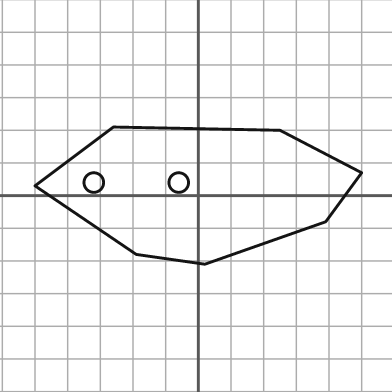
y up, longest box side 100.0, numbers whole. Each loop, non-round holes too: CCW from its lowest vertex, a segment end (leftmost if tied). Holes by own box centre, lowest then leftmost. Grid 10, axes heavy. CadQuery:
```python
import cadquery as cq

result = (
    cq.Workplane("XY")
    .moveTo(2.0, -21.0)
    .lineTo(39.0, -8.0)
    .lineTo(50.0, 7.0)
    .lineTo(25.0, 20.0)
    .lineTo(-26.0, 21.0)
    .lineTo(-50.0, 3.0)
    .lineTo(-19.0, -18.0)
    .close()
    .moveTo(-32.0, 4.0)
    .circle(3.0)
    .moveTo(-6.0, 4.0)
    .circle(3.0)
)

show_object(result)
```